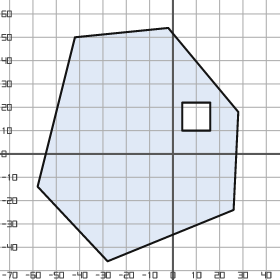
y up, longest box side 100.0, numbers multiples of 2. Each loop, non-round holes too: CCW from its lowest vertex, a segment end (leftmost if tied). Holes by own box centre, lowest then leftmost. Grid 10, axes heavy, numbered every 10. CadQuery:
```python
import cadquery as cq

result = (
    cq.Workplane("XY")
    .moveTo(-28.0, -46.0)
    .lineTo(26.0, -24.0)
    .lineTo(28.0, 18.0)
    .lineTo(-2.0, 54.0)
    .lineTo(-42.0, 50.0)
    .lineTo(-58.0, -14.0)
    .close()
    .moveTo(4.0, 10.0)
    .lineTo(16.0, 10.0)
    .lineTo(16.0, 22.0)
    .lineTo(4.0, 22.0)
    .close()
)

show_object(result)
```